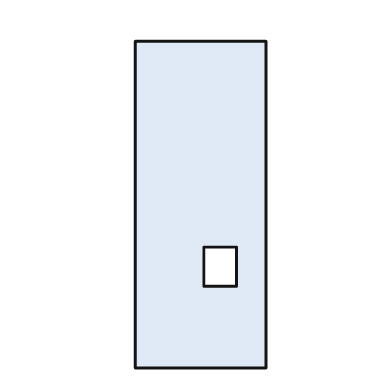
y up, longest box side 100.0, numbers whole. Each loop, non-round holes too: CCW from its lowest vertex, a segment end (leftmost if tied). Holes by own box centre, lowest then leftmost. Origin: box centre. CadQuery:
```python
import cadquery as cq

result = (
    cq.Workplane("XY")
    .moveTo(-20.0, -50.0)
    .lineTo(20.0, -50.0)
    .lineTo(20.0, 50.0)
    .lineTo(-20.0, 50.0)
    .close()
    .moveTo(1.0, -25.0)
    .lineTo(11.0, -25.0)
    .lineTo(11.0, -13.0)
    .lineTo(1.0, -13.0)
    .close()
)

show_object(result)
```